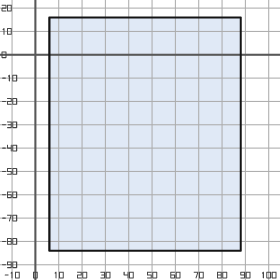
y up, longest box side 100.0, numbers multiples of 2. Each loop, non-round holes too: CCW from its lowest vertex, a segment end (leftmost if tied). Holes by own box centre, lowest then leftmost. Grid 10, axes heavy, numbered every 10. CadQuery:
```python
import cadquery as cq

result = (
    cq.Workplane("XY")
    .moveTo(6.0, -84.0)
    .lineTo(88.0, -84.0)
    .lineTo(88.0, 16.0)
    .lineTo(6.0, 16.0)
    .close()
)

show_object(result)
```